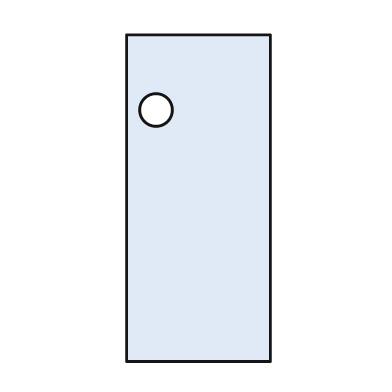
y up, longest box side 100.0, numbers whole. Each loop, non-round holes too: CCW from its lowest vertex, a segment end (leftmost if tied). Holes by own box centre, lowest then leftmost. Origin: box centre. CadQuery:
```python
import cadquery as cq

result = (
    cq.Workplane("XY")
    .moveTo(-22.0, -50.0)
    .lineTo(22.0, -50.0)
    .lineTo(22.0, 50.0)
    .lineTo(-22.0, 50.0)
    .close()
    .moveTo(-13.0, 27.0)
    .circle(5.0)
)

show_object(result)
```